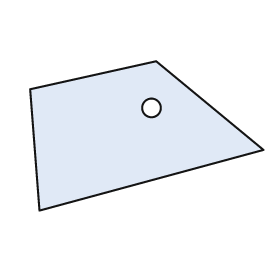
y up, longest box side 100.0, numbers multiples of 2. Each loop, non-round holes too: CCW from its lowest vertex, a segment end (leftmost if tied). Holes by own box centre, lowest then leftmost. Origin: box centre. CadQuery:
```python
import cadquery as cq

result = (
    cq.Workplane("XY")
    .moveTo(-46.0, -32.0)
    .lineTo(50.0, -6.0)
    .lineTo(4.0, 32.0)
    .lineTo(-50.0, 20.0)
    .close()
    .moveTo(2.0, 12.0)
    .circle(4.0)
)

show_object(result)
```